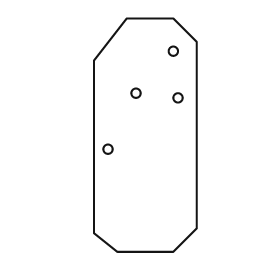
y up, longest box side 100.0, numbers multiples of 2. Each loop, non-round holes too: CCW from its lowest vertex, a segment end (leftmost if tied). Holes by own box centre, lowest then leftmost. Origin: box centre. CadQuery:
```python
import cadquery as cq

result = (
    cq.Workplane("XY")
    .moveTo(-12.0, -50.0)
    .lineTo(12.0, -50.0)
    .lineTo(22.0, -40.0)
    .lineTo(22.0, 40.0)
    .lineTo(12.0, 50.0)
    .lineTo(-8.0, 50.0)
    .lineTo(-22.0, 32.0)
    .lineTo(-22.0, -42.0)
    .close()
    .moveTo(-16.0, -6.0)
    .circle(2.0)
    .moveTo(14.0, 16.0)
    .circle(2.0)
    .moveTo(-4.0, 18.0)
    .circle(2.0)
    .moveTo(12.0, 36.0)
    .circle(2.0)
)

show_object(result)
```